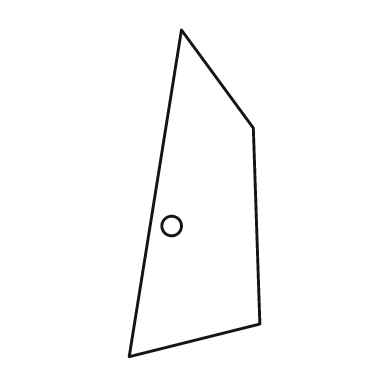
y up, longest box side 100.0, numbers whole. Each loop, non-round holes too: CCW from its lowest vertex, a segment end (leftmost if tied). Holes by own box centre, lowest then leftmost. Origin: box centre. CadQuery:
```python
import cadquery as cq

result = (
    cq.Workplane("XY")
    .moveTo(-20.0, -50.0)
    .lineTo(20.0, -40.0)
    .lineTo(18.0, 20.0)
    .lineTo(-4.0, 50.0)
    .close()
    .moveTo(-7.0, -10.0)
    .circle(3.0)
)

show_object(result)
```